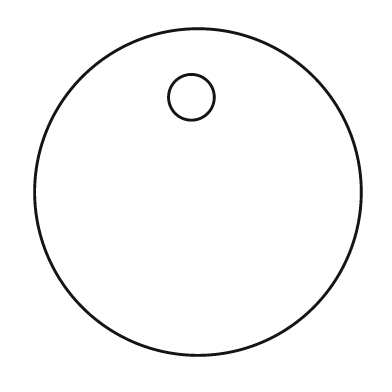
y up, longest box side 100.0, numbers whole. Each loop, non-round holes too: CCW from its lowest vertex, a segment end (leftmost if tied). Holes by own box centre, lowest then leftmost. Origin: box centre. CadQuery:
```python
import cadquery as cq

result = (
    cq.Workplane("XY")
    .moveTo(0.0, 0.0)
    .circle(50.0)
    .moveTo(-2.0, 29.0)
    .circle(7.0)
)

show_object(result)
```